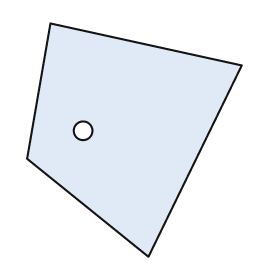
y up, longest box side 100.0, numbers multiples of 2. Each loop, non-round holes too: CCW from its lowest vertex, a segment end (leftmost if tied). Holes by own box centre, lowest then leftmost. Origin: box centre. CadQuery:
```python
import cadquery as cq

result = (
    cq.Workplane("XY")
    .moveTo(6.0, -50.0)
    .lineTo(46.0, 32.0)
    .lineTo(-36.0, 50.0)
    .lineTo(-46.0, -8.0)
    .close()
    .moveTo(-22.0, 4.0)
    .circle(4.0)
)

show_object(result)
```